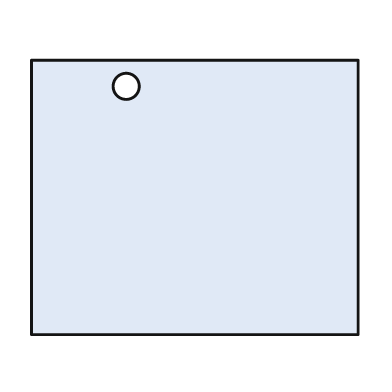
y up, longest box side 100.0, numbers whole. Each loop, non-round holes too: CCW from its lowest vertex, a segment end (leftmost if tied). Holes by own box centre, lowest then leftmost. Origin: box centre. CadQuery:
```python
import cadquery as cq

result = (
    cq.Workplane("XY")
    .moveTo(-50.0, -42.0)
    .lineTo(50.0, -42.0)
    .lineTo(50.0, 42.0)
    .lineTo(-50.0, 42.0)
    .close()
    .moveTo(-21.0, 34.0)
    .circle(4.0)
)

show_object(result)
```